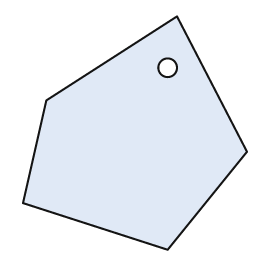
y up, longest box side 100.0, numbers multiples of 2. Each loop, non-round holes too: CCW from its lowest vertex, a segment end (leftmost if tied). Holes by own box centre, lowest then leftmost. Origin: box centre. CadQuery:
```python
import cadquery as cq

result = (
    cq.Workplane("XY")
    .moveTo(14.0, -50.0)
    .lineTo(48.0, -8.0)
    .lineTo(18.0, 50.0)
    .lineTo(-38.0, 14.0)
    .lineTo(-48.0, -30.0)
    .close()
    .moveTo(14.0, 28.0)
    .circle(4.0)
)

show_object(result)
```